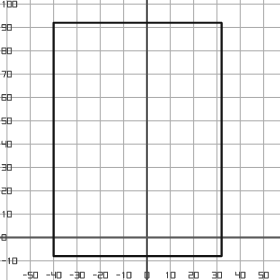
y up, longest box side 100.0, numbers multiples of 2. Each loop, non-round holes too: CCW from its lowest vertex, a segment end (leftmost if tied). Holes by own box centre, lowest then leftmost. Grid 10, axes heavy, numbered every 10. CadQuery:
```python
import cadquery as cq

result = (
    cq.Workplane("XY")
    .moveTo(-40.0, -8.0)
    .lineTo(32.0, -8.0)
    .lineTo(32.0, 92.0)
    .lineTo(-40.0, 92.0)
    .close()
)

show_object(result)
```